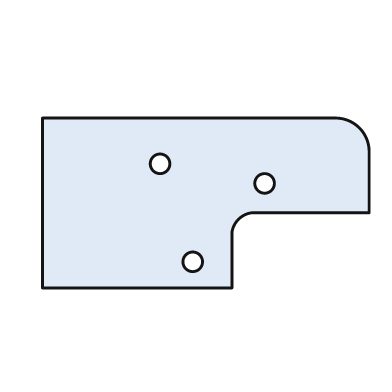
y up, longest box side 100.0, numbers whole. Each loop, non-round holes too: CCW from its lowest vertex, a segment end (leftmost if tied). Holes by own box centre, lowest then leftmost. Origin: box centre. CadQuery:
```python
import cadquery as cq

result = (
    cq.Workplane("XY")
    .moveTo(-50.0, -26.0)
    .lineTo(8.0, -26.0)
    .lineTo(8.0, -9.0)
    .threePointArc((10.0, -5.0), (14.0, -3.0))
    .lineTo(50.0, -3.0)
    .lineTo(50.0, 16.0)
    .threePointArc((47.0, 23.0), (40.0, 26.0))
    .lineTo(-50.0, 26.0)
    .close()
    .moveTo(-4.0, -18.0)
    .circle(3.0)
    .moveTo(18.0, 6.0)
    .circle(3.0)
    .moveTo(-14.0, 12.0)
    .circle(3.0)
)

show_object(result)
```